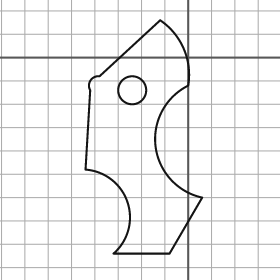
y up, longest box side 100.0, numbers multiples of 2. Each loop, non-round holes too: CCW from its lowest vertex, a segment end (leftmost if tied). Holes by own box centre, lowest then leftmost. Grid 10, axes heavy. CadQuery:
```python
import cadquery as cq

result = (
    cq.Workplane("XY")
    .moveTo(-32.0, -84.0)
    .lineTo(-8.0, -84.0)
    .lineTo(6.0, -60.0)
    .threePointArc((-14.0, -38.0), (0.0, -12.0))
    .threePointArc((-2.0, 4.0), (-12.0, 16.0))
    .lineTo(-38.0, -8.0)
    .threePointArc((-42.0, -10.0), (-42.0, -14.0))
    .lineTo(-44.0, -48.0)
    .threePointArc((-26.0, -62.0), (-32.0, -84.0))
    .close()
    .moveTo(-24.0, -14.0)
    .circle(6.0)
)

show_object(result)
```